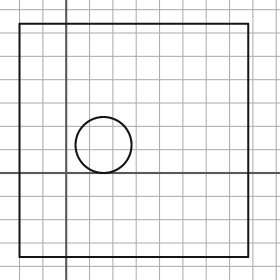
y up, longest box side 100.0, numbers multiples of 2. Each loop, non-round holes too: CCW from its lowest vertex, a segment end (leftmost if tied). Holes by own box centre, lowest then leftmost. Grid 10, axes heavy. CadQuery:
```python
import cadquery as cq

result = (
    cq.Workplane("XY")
    .moveTo(-20.0, -36.0)
    .lineTo(78.0, -36.0)
    .lineTo(78.0, 64.0)
    .lineTo(-20.0, 64.0)
    .close()
    .moveTo(16.0, 12.0)
    .circle(12.0)
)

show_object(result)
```